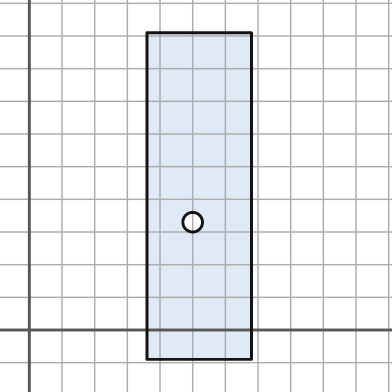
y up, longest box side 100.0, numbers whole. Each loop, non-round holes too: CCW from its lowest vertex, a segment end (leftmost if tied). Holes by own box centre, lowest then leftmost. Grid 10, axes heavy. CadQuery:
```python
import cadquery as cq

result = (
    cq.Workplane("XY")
    .moveTo(36.0, -9.0)
    .lineTo(68.0, -9.0)
    .lineTo(68.0, 91.0)
    .lineTo(36.0, 91.0)
    .close()
    .moveTo(50.0, 33.0)
    .circle(3.0)
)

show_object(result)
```